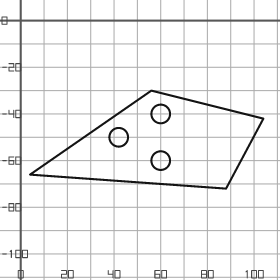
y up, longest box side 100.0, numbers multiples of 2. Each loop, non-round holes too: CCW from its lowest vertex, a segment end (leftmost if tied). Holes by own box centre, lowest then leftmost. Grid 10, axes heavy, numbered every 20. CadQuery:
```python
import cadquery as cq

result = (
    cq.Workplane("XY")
    .moveTo(88.0, -72.0)
    .lineTo(104.0, -42.0)
    .lineTo(56.0, -30.0)
    .lineTo(4.0, -66.0)
    .close()
    .moveTo(60.0, -60.0)
    .circle(4.0)
    .moveTo(42.0, -50.0)
    .circle(4.0)
    .moveTo(60.0, -40.0)
    .circle(4.0)
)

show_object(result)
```